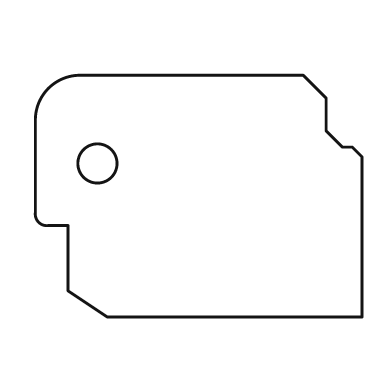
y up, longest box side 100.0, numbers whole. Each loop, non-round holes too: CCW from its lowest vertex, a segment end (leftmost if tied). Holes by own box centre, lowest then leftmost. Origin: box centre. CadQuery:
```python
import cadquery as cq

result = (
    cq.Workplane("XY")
    .moveTo(-28.0, -37.0)
    .lineTo(50.0, -37.0)
    .lineTo(50.0, 12.0)
    .lineTo(47.0, 15.0)
    .lineTo(44.0, 15.0)
    .lineTo(39.0, 20.0)
    .lineTo(39.0, 30.0)
    .lineTo(32.0, 37.0)
    .lineTo(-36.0, 37.0)
    .threePointArc((-46.0, 33.0), (-50.0, 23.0))
    .lineTo(-50.0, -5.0)
    .threePointArc((-49.0, -8.0), (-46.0, -9.0))
    .lineTo(-40.0, -9.0)
    .lineTo(-40.0, -29.0)
    .close()
    .moveTo(-31.0, 10.0)
    .circle(6.0)
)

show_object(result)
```